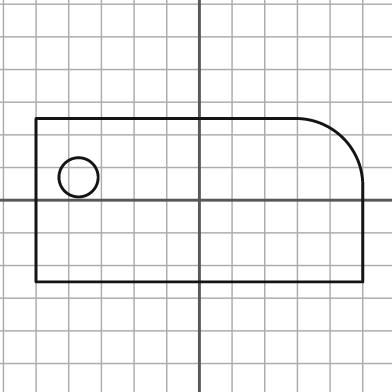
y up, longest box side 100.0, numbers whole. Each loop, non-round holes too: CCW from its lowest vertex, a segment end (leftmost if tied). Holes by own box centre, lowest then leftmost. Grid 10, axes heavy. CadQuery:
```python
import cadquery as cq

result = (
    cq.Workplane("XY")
    .moveTo(-50.0, -25.0)
    .lineTo(50.0, -25.0)
    .lineTo(50.0, 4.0)
    .threePointArc((44.0, 19.0), (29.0, 25.0))
    .lineTo(-50.0, 25.0)
    .close()
    .moveTo(-37.0, 7.0)
    .circle(6.0)
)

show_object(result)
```